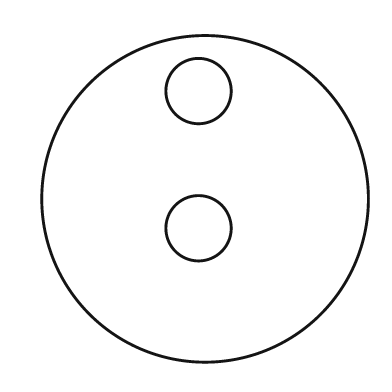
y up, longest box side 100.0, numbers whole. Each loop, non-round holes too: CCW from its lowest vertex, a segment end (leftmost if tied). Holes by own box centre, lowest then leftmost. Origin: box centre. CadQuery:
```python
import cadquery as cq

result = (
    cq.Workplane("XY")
    .moveTo(0.0, 0.0)
    .circle(50.0)
    .moveTo(-2.0, -9.0)
    .circle(10.0)
    .moveTo(-2.0, 33.0)
    .circle(10.0)
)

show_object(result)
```